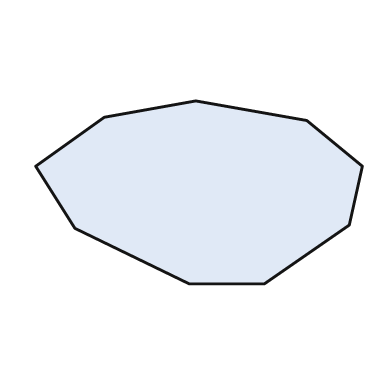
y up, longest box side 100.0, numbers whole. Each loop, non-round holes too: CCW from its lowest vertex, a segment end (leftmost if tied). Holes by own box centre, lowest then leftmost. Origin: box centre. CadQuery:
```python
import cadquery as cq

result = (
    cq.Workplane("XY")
    .moveTo(-3.0, -28.0)
    .lineTo(20.0, -28.0)
    .lineTo(46.0, -10.0)
    .lineTo(50.0, 8.0)
    .lineTo(33.0, 22.0)
    .lineTo(-1.0, 28.0)
    .lineTo(-29.0, 23.0)
    .lineTo(-50.0, 8.0)
    .lineTo(-38.0, -11.0)
    .close()
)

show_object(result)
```